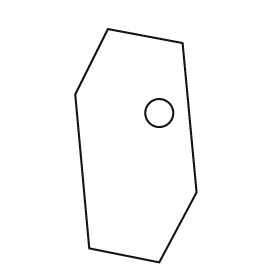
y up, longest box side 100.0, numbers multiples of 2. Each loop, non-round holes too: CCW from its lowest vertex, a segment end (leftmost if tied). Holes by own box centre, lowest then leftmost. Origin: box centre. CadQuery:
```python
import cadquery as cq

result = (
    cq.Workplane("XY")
    .moveTo(10.0, -50.0)
    .lineTo(26.0, -20.0)
    .lineTo(20.0, 44.0)
    .lineTo(-12.0, 50.0)
    .lineTo(-26.0, 22.0)
    .lineTo(-20.0, -44.0)
    .close()
    .moveTo(10.0, 14.0)
    .circle(6.0)
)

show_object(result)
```